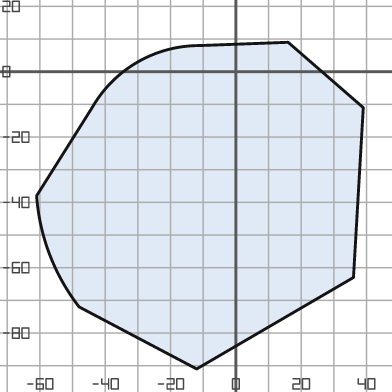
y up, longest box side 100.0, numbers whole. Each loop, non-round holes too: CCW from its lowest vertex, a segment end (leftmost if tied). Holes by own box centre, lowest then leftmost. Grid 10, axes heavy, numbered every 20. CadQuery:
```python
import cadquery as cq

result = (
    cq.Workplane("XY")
    .moveTo(-12.0, -91.0)
    .lineTo(36.0, -63.0)
    .lineTo(39.0, -11.0)
    .lineTo(16.0, 9.0)
    .lineTo(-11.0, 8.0)
    .threePointArc((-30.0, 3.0), (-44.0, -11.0))
    .lineTo(-61.0, -38.0)
    .threePointArc((-57.0, -56.0), (-48.0, -72.0))
    .close()
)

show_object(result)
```